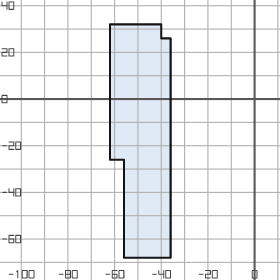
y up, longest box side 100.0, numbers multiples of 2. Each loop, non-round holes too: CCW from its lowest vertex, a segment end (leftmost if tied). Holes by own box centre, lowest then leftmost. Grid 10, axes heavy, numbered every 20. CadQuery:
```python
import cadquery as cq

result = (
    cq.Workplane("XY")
    .moveTo(-56.0, -68.0)
    .lineTo(-36.0, -68.0)
    .lineTo(-36.0, 26.0)
    .lineTo(-40.0, 26.0)
    .lineTo(-40.0, 32.0)
    .lineTo(-62.0, 32.0)
    .lineTo(-62.0, -26.0)
    .lineTo(-56.0, -26.0)
    .close()
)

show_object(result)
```